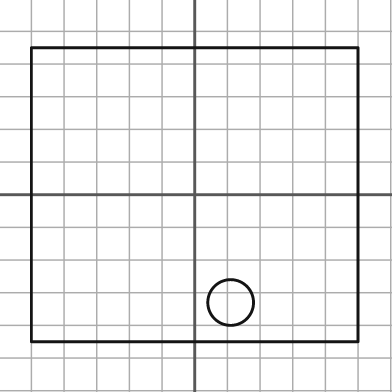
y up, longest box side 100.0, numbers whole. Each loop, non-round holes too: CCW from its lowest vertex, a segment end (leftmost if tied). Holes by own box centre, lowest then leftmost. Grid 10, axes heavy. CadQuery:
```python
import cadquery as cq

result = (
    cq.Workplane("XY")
    .moveTo(-50.0, -45.0)
    .lineTo(50.0, -45.0)
    .lineTo(50.0, 45.0)
    .lineTo(-50.0, 45.0)
    .close()
    .moveTo(11.0, -33.0)
    .circle(7.0)
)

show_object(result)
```